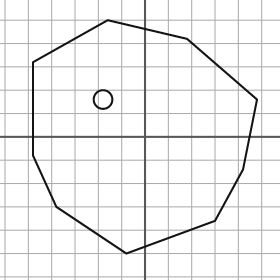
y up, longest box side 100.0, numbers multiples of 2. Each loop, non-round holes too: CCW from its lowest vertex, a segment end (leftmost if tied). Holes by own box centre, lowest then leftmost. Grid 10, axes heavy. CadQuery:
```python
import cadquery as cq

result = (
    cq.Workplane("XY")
    .moveTo(-8.0, -50.0)
    .lineTo(30.0, -36.0)
    .lineTo(42.0, -14.0)
    .lineTo(48.0, 16.0)
    .lineTo(18.0, 42.0)
    .lineTo(-16.0, 50.0)
    .lineTo(-48.0, 32.0)
    .lineTo(-48.0, -8.0)
    .lineTo(-38.0, -30.0)
    .close()
    .moveTo(-18.0, 16.0)
    .circle(4.0)
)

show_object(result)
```